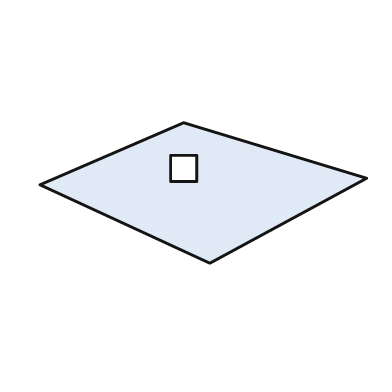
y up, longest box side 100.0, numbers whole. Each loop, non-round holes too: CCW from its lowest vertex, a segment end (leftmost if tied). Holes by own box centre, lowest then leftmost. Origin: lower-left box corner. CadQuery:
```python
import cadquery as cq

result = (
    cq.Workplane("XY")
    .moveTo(52.0, 0.0)
    .lineTo(100.0, 26.0)
    .lineTo(44.0, 43.0)
    .lineTo(0.0, 24.0)
    .close()
    .moveTo(40.0, 25.0)
    .lineTo(48.0, 25.0)
    .lineTo(48.0, 33.0)
    .lineTo(40.0, 33.0)
    .close()
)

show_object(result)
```